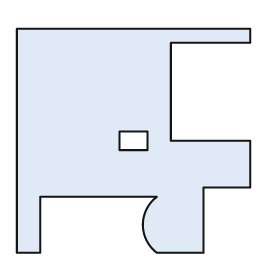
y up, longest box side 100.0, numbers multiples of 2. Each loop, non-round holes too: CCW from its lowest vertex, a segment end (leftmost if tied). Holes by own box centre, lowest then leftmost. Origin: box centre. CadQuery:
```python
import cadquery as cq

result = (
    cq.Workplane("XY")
    .moveTo(-50.0, -48.0)
    .lineTo(-40.0, -48.0)
    .lineTo(-40.0, -24.0)
    .lineTo(10.0, -24.0)
    .threePointArc((4.0, -36.0), (10.0, -48.0))
    .lineTo(30.0, -48.0)
    .lineTo(30.0, -20.0)
    .lineTo(50.0, -20.0)
    .lineTo(50.0, 0.0)
    .lineTo(16.0, 0.0)
    .lineTo(16.0, 42.0)
    .lineTo(50.0, 42.0)
    .lineTo(50.0, 48.0)
    .lineTo(-50.0, 48.0)
    .close()
    .moveTo(-6.0, -4.0)
    .lineTo(6.0, -4.0)
    .lineTo(6.0, 4.0)
    .lineTo(-6.0, 4.0)
    .close()
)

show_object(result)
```